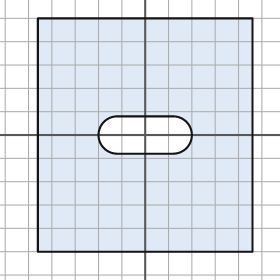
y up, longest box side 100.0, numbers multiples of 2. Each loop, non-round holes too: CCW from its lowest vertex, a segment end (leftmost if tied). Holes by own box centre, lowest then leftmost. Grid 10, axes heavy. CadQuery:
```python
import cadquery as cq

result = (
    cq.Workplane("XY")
    .moveTo(-46.0, -50.0)
    .lineTo(46.0, -50.0)
    .lineTo(46.0, 50.0)
    .lineTo(-46.0, 50.0)
    .close()
    .moveTo(-12.0, -8.0)
    .lineTo(12.0, -8.0)
    .threePointArc((20.0, 0.0), (12.0, 8.0))
    .lineTo(-12.0, 8.0)
    .threePointArc((-20.0, 0.0), (-12.0, -8.0))
    .close()
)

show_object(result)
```